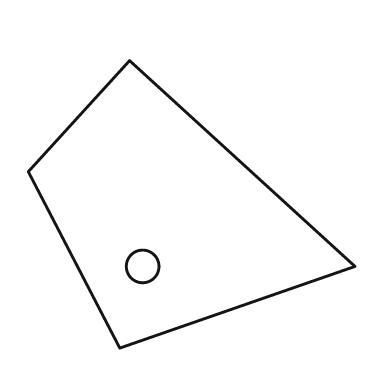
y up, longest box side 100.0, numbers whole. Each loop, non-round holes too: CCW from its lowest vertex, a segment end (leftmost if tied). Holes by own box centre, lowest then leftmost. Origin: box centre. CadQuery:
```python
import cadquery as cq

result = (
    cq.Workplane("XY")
    .moveTo(-22.0, -44.0)
    .lineTo(50.0, -19.0)
    .lineTo(-19.0, 44.0)
    .lineTo(-50.0, 10.0)
    .close()
    .moveTo(-15.0, -19.0)
    .circle(5.0)
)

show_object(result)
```